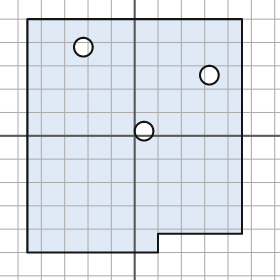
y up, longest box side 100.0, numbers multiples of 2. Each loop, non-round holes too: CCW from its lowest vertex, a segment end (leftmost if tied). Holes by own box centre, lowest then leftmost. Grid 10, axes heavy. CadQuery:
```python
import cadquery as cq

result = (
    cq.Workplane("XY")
    .moveTo(-46.0, -50.0)
    .lineTo(10.0, -50.0)
    .lineTo(10.0, -42.0)
    .lineTo(46.0, -42.0)
    .lineTo(46.0, 50.0)
    .lineTo(-46.0, 50.0)
    .close()
    .moveTo(4.0, 2.0)
    .circle(4.0)
    .moveTo(32.0, 26.0)
    .circle(4.0)
    .moveTo(-22.0, 38.0)
    .circle(4.0)
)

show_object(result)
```